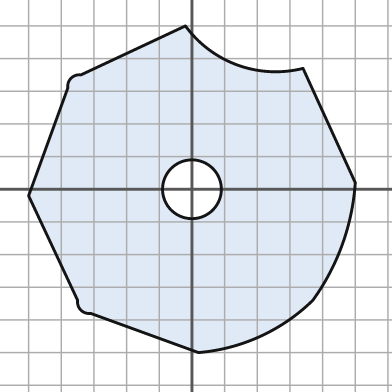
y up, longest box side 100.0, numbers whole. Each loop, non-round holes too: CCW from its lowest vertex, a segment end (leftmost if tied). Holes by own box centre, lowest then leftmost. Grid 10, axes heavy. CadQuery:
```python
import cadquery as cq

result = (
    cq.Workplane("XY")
    .moveTo(2.0, -50.0)
    .threePointArc((21.0, -45.0), (37.0, -34.0))
    .threePointArc((46.0, -17.0), (50.0, 2.0))
    .lineTo(34.0, 37.0)
    .threePointArc((14.0, 38.0), (-2.0, 50.0))
    .lineTo(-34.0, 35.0)
    .threePointArc((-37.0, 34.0), (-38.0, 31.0))
    .lineTo(-50.0, -2.0)
    .lineTo(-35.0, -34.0)
    .threePointArc((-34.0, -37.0), (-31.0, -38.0))
    .close()
    .moveTo(0.0, 0.0)
    .circle(9.0)
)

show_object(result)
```